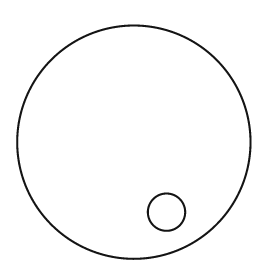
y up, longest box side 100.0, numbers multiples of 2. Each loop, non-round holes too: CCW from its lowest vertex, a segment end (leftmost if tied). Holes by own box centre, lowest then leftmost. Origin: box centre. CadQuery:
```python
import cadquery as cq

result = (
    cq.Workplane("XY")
    .moveTo(0.0, 0.0)
    .circle(50.0)
    .moveTo(14.0, -30.0)
    .circle(8.0)
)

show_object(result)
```